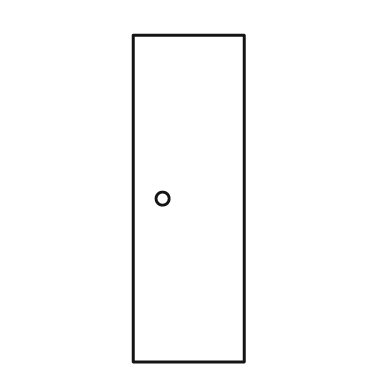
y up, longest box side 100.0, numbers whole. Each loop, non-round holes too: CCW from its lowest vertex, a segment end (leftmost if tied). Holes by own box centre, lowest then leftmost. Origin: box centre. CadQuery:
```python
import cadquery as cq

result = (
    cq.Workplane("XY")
    .moveTo(-17.0, -50.0)
    .lineTo(17.0, -50.0)
    .lineTo(17.0, 50.0)
    .lineTo(-17.0, 50.0)
    .close()
    .moveTo(-8.0, 0.0)
    .circle(2.0)
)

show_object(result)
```